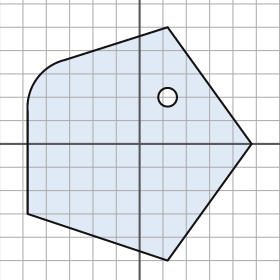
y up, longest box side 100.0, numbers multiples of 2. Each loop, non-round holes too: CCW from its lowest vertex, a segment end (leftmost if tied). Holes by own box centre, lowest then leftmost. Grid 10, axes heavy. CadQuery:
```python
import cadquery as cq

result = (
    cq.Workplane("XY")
    .moveTo(12.0, -50.0)
    .lineTo(48.0, 0.0)
    .lineTo(12.0, 50.0)
    .lineTo(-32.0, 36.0)
    .threePointArc((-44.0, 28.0), (-48.0, 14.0))
    .lineTo(-48.0, -30.0)
    .close()
    .moveTo(12.0, 20.0)
    .circle(4.0)
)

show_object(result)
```